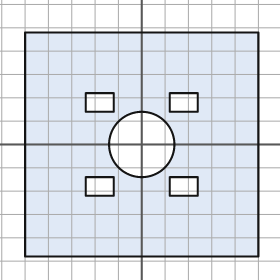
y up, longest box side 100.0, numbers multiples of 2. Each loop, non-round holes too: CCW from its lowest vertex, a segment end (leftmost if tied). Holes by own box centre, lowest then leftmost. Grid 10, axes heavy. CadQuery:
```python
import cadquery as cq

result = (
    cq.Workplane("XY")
    .moveTo(-50.0, -48.0)
    .lineTo(50.0, -48.0)
    .lineTo(50.0, 48.0)
    .lineTo(-50.0, 48.0)
    .close()
    .moveTo(-24.0, -22.0)
    .lineTo(-12.0, -22.0)
    .lineTo(-12.0, -14.0)
    .lineTo(-24.0, -14.0)
    .close()
    .moveTo(12.0, -22.0)
    .lineTo(24.0, -22.0)
    .lineTo(24.0, -14.0)
    .lineTo(12.0, -14.0)
    .close()
    .moveTo(0.0, 0.0)
    .circle(14.0)
    .moveTo(-24.0, 14.0)
    .lineTo(-12.0, 14.0)
    .lineTo(-12.0, 22.0)
    .lineTo(-24.0, 22.0)
    .close()
    .moveTo(12.0, 14.0)
    .lineTo(24.0, 14.0)
    .lineTo(24.0, 22.0)
    .lineTo(12.0, 22.0)
    .close()
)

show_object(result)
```